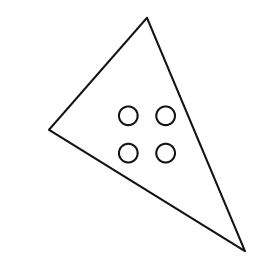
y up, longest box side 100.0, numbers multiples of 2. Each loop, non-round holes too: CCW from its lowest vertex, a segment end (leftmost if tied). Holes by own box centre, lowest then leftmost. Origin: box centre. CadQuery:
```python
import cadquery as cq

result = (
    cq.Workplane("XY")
    .moveTo(42.0, -50.0)
    .lineTo(0.0, 50.0)
    .lineTo(-42.0, 2.0)
    .close()
    .moveTo(-8.0, -8.0)
    .circle(4.0)
    .moveTo(8.0, -8.0)
    .circle(4.0)
    .moveTo(-8.0, 8.0)
    .circle(4.0)
    .moveTo(8.0, 8.0)
    .circle(4.0)
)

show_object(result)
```